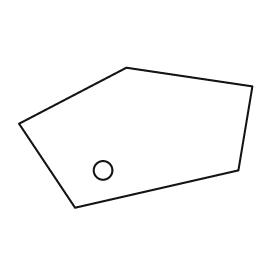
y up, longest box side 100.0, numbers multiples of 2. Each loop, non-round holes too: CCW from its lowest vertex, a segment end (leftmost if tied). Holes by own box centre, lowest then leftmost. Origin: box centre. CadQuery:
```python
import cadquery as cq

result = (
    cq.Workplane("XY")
    .moveTo(-26.0, -30.0)
    .lineTo(44.0, -14.0)
    .lineTo(50.0, 22.0)
    .lineTo(-4.0, 30.0)
    .lineTo(-50.0, 6.0)
    .close()
    .moveTo(-14.0, -14.0)
    .circle(4.0)
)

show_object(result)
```